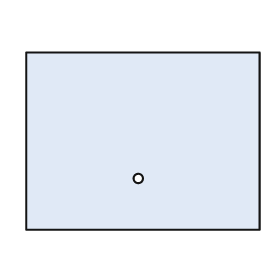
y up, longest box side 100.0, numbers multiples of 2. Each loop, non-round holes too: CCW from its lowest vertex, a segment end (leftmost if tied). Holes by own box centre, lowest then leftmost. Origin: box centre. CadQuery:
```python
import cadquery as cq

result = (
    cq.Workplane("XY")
    .moveTo(-50.0, -38.0)
    .lineTo(50.0, -38.0)
    .lineTo(50.0, 38.0)
    .lineTo(-50.0, 38.0)
    .close()
    .moveTo(-2.0, -16.0)
    .circle(2.0)
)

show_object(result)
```